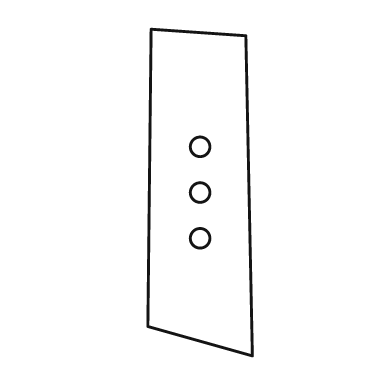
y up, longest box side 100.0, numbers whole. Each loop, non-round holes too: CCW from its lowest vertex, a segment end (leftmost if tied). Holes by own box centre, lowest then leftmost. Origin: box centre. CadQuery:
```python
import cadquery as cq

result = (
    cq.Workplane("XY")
    .moveTo(16.0, -50.0)
    .lineTo(14.0, 48.0)
    .lineTo(-15.0, 50.0)
    .lineTo(-16.0, -41.0)
    .close()
    .moveTo(0.0, -14.0)
    .circle(3.0)
    .moveTo(0.0, 0.0)
    .circle(3.0)
    .moveTo(0.0, 14.0)
    .circle(3.0)
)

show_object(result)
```